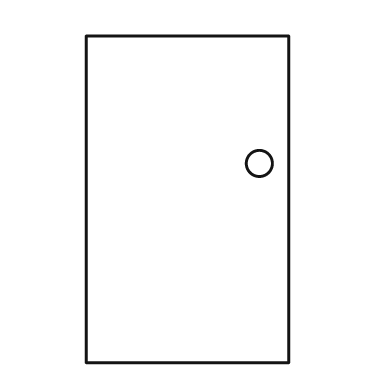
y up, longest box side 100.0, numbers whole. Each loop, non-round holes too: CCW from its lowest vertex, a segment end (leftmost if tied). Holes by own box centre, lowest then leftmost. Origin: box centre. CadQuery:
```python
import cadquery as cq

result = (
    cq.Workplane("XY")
    .moveTo(-31.0, -50.0)
    .lineTo(31.0, -50.0)
    .lineTo(31.0, 50.0)
    .lineTo(-31.0, 50.0)
    .close()
    .moveTo(22.0, 11.0)
    .circle(4.0)
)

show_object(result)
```